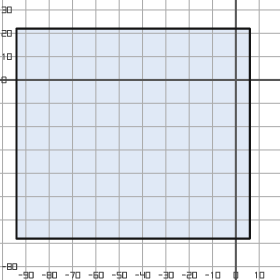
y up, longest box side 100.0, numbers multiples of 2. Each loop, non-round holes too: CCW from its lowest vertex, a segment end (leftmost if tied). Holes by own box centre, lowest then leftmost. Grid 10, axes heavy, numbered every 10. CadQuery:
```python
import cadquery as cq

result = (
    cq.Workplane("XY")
    .moveTo(-94.0, -68.0)
    .lineTo(6.0, -68.0)
    .lineTo(6.0, 22.0)
    .lineTo(-94.0, 22.0)
    .close()
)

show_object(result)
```